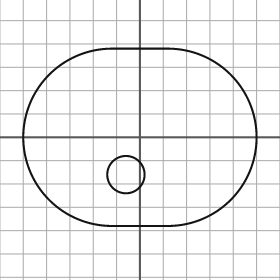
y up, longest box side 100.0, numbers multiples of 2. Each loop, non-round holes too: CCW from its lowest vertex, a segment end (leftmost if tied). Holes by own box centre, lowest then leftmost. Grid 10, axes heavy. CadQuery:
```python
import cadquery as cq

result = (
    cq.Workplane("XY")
    .moveTo(-12.0, -38.0)
    .lineTo(12.0, -38.0)
    .threePointArc((50.0, 0.0), (12.0, 38.0))
    .lineTo(-12.0, 38.0)
    .threePointArc((-50.0, 0.0), (-12.0, -38.0))
    .close()
    .moveTo(-6.0, -16.0)
    .circle(8.0)
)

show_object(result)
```